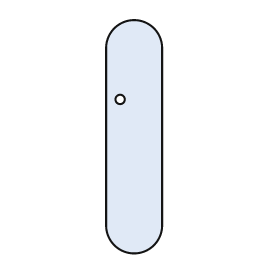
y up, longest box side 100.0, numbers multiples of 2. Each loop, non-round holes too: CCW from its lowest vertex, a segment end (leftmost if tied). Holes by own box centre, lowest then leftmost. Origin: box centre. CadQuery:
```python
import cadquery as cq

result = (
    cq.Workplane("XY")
    .moveTo(-12.0, -38.0)
    .threePointArc((0.0, -50.0), (12.0, -38.0))
    .lineTo(12.0, 38.0)
    .threePointArc((0.0, 50.0), (-12.0, 38.0))
    .close()
    .moveTo(-6.0, 16.0)
    .circle(2.0)
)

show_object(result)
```